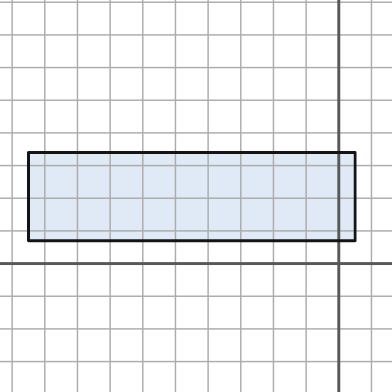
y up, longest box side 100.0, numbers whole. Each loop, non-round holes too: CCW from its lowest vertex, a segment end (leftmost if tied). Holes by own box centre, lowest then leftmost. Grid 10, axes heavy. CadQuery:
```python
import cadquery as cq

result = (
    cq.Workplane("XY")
    .moveTo(-95.0, 7.0)
    .lineTo(5.0, 7.0)
    .lineTo(5.0, 34.0)
    .lineTo(-95.0, 34.0)
    .close()
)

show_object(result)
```